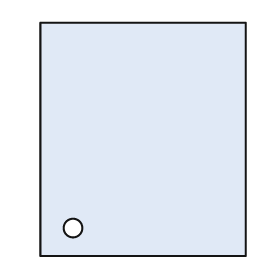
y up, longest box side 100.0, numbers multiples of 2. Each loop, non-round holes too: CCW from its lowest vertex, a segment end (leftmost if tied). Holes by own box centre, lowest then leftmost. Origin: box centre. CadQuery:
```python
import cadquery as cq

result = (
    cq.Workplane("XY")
    .moveTo(-44.0, -50.0)
    .lineTo(44.0, -50.0)
    .lineTo(44.0, 50.0)
    .lineTo(-44.0, 50.0)
    .close()
    .moveTo(-30.0, -38.0)
    .circle(4.0)
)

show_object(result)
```